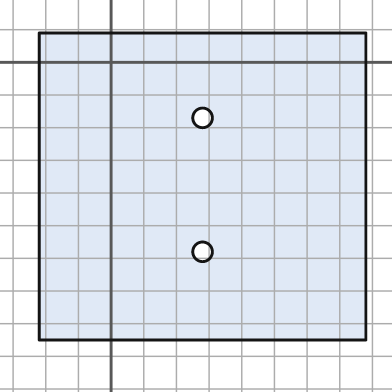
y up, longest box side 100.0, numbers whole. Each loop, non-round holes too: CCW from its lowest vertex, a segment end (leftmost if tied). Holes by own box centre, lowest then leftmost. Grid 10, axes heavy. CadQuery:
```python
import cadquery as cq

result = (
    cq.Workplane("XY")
    .moveTo(-22.0, -85.0)
    .lineTo(78.0, -85.0)
    .lineTo(78.0, 9.0)
    .lineTo(-22.0, 9.0)
    .close()
    .moveTo(28.0, -58.0)
    .circle(3.0)
    .moveTo(28.0, -17.0)
    .circle(3.0)
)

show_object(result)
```